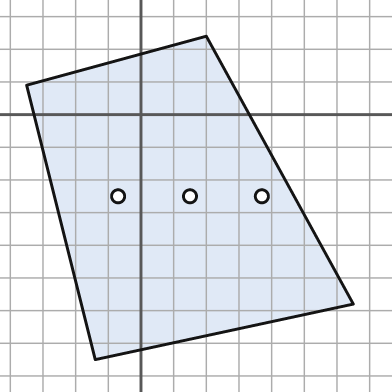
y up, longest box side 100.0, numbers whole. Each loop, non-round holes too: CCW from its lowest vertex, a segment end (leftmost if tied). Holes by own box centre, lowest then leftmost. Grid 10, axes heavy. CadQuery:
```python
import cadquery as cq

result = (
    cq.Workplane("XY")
    .moveTo(-14.0, -75.0)
    .lineTo(65.0, -58.0)
    .lineTo(20.0, 24.0)
    .lineTo(-35.0, 9.0)
    .close()
    .moveTo(-7.0, -25.0)
    .circle(2.0)
    .moveTo(15.0, -25.0)
    .circle(2.0)
    .moveTo(37.0, -25.0)
    .circle(2.0)
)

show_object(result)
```